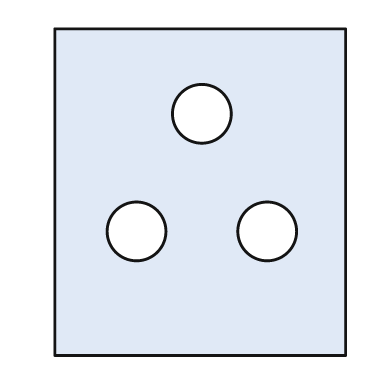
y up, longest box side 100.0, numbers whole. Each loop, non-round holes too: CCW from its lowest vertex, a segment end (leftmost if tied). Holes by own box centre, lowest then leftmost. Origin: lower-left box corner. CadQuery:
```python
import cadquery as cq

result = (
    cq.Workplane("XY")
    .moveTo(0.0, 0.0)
    .lineTo(89.0, 0.0)
    .lineTo(89.0, 100.0)
    .lineTo(0.0, 100.0)
    .close()
    .moveTo(25.0, 38.0)
    .circle(9.0)
    .moveTo(65.0, 38.0)
    .circle(9.0)
    .moveTo(45.0, 74.0)
    .circle(9.0)
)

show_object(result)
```